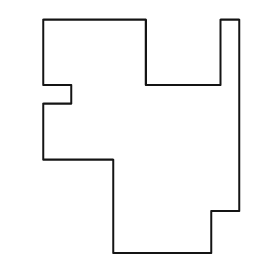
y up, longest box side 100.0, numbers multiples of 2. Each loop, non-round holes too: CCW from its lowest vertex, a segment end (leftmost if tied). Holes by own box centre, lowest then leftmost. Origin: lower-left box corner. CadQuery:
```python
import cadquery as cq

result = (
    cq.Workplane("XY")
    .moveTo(30.0, 0.0)
    .lineTo(72.0, 0.0)
    .lineTo(72.0, 18.0)
    .lineTo(84.0, 18.0)
    .lineTo(84.0, 100.0)
    .lineTo(76.0, 100.0)
    .lineTo(76.0, 72.0)
    .lineTo(44.0, 72.0)
    .lineTo(44.0, 100.0)
    .lineTo(0.0, 100.0)
    .lineTo(0.0, 72.0)
    .lineTo(12.0, 72.0)
    .lineTo(12.0, 64.0)
    .lineTo(0.0, 64.0)
    .lineTo(0.0, 40.0)
    .lineTo(30.0, 40.0)
    .close()
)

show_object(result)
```